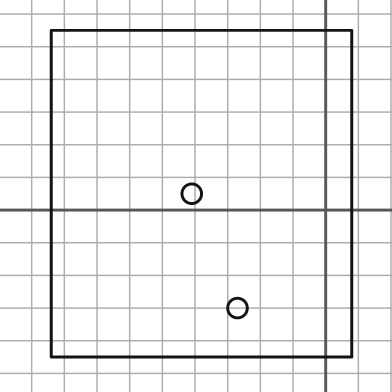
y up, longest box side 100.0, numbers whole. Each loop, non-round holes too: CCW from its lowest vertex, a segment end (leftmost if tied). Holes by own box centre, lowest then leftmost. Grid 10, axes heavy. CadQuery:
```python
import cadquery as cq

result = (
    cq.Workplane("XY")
    .moveTo(-84.0, -45.0)
    .lineTo(8.0, -45.0)
    .lineTo(8.0, 55.0)
    .lineTo(-84.0, 55.0)
    .close()
    .moveTo(-27.0, -30.0)
    .circle(3.0)
    .moveTo(-41.0, 5.0)
    .circle(3.0)
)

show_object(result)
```